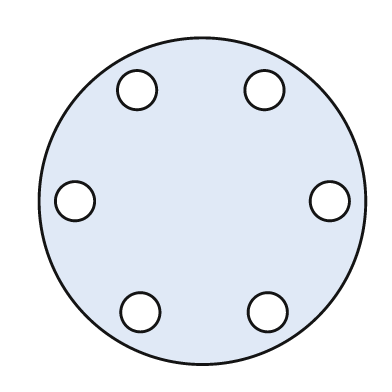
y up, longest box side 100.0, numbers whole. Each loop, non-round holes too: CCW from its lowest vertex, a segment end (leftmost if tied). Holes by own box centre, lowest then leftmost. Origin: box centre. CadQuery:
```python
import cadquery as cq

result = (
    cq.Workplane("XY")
    .moveTo(0.0, 0.0)
    .circle(50.0)
    .moveTo(-19.0, -34.0)
    .circle(6.0)
    .moveTo(20.0, -34.0)
    .circle(6.0)
    .moveTo(-39.0, 0.0)
    .circle(6.0)
    .moveTo(39.0, 0.0)
    .circle(6.0)
    .moveTo(-20.0, 34.0)
    .circle(6.0)
    .moveTo(19.0, 34.0)
    .circle(6.0)
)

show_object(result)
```